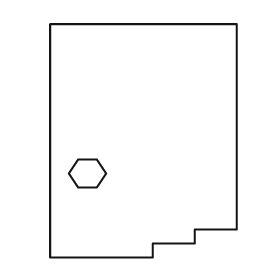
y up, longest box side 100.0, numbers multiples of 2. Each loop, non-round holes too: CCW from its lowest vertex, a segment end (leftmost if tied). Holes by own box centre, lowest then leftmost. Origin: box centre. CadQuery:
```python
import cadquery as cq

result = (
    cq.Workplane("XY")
    .moveTo(-40.0, -50.0)
    .lineTo(4.0, -50.0)
    .lineTo(4.0, -44.0)
    .lineTo(22.0, -44.0)
    .lineTo(22.0, -38.0)
    .lineTo(40.0, -38.0)
    .lineTo(40.0, 50.0)
    .lineTo(-40.0, 50.0)
    .close()
    .moveTo(-28.0, -20.0)
    .lineTo(-20.0, -20.0)
    .lineTo(-16.0, -14.0)
    .lineTo(-20.0, -8.0)
    .lineTo(-28.0, -8.0)
    .lineTo(-32.0, -14.0)
    .close()
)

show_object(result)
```